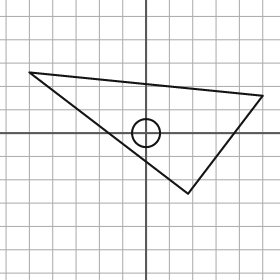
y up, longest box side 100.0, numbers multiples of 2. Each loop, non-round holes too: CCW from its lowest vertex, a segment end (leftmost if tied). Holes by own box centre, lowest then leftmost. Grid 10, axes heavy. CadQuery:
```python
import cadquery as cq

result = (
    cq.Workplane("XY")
    .moveTo(18.0, -26.0)
    .lineTo(50.0, 16.0)
    .lineTo(-50.0, 26.0)
    .close()
    .moveTo(0.0, 0.0)
    .circle(6.0)
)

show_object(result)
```